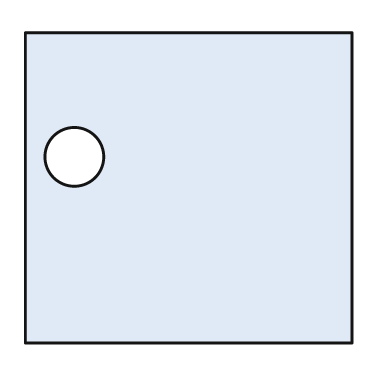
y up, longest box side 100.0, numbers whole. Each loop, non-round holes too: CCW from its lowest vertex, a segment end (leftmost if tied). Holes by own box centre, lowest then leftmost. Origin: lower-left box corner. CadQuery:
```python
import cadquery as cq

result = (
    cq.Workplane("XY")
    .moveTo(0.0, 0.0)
    .lineTo(100.0, 0.0)
    .lineTo(100.0, 95.0)
    .lineTo(0.0, 95.0)
    .close()
    .moveTo(15.0, 57.0)
    .circle(9.0)
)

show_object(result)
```